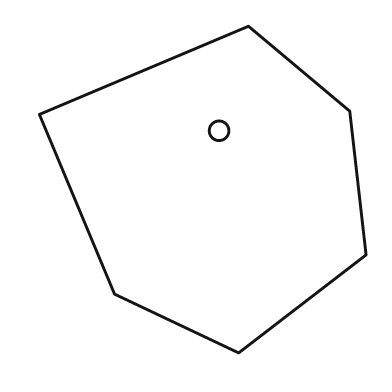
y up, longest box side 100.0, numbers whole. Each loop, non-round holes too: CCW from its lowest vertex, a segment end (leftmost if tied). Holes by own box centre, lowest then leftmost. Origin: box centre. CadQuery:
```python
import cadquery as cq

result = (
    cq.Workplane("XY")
    .moveTo(11.0, -50.0)
    .lineTo(50.0, -20.0)
    .lineTo(45.0, 24.0)
    .lineTo(14.0, 50.0)
    .lineTo(-50.0, 23.0)
    .lineTo(-27.0, -32.0)
    .close()
    .moveTo(5.0, 18.0)
    .circle(3.0)
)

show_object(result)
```